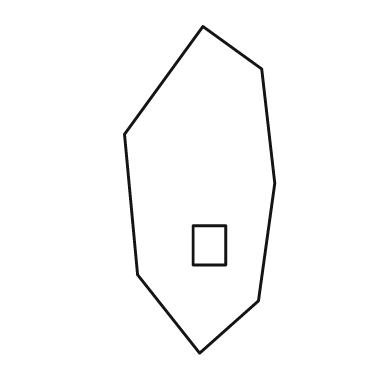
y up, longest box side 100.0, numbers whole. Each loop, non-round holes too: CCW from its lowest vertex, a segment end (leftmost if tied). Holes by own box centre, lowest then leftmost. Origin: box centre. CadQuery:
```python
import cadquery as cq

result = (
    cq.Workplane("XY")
    .moveTo(0.0, -50.0)
    .lineTo(18.0, -34.0)
    .lineTo(23.0, 2.0)
    .lineTo(19.0, 37.0)
    .lineTo(1.0, 50.0)
    .lineTo(-23.0, 17.0)
    .lineTo(-19.0, -26.0)
    .close()
    .moveTo(-2.0, -23.0)
    .lineTo(8.0, -23.0)
    .lineTo(8.0, -11.0)
    .lineTo(-2.0, -11.0)
    .close()
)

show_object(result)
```